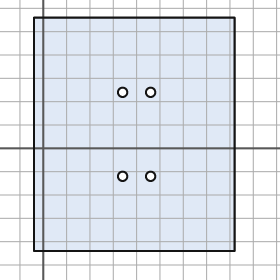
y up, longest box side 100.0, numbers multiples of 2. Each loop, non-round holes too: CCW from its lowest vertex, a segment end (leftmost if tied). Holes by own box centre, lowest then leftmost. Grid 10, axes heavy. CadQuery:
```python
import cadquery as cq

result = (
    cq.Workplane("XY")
    .moveTo(-4.0, -44.0)
    .lineTo(82.0, -44.0)
    .lineTo(82.0, 56.0)
    .lineTo(-4.0, 56.0)
    .close()
    .moveTo(34.0, -12.0)
    .circle(2.0)
    .moveTo(46.0, -12.0)
    .circle(2.0)
    .moveTo(34.0, 24.0)
    .circle(2.0)
    .moveTo(46.0, 24.0)
    .circle(2.0)
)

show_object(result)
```